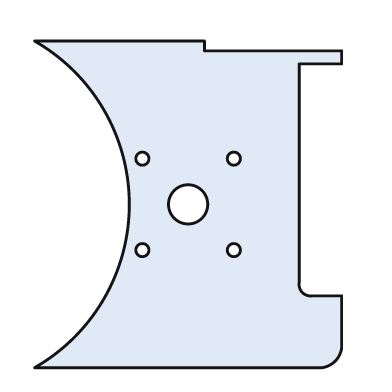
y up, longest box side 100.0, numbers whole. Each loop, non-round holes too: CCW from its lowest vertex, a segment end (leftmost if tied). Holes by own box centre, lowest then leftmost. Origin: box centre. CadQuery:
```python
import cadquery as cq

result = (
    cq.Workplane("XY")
    .moveTo(-47.0, -50.0)
    .lineTo(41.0, -50.0)
    .threePointArc((45.0, -48.0), (47.0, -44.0))
    .lineTo(47.0, -28.0)
    .lineTo(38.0, -28.0)
    .threePointArc((35.0, -27.0), (34.0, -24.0))
    .lineTo(34.0, 43.0)
    .lineTo(47.0, 43.0)
    .lineTo(47.0, 47.0)
    .lineTo(5.0, 47.0)
    .lineTo(5.0, 50.0)
    .lineTo(-47.0, 50.0)
    .threePointArc((-18.0, 0.0), (-47.0, -50.0))
    .close()
    .moveTo(-14.0, -14.0)
    .circle(2.0)
    .moveTo(14.0, -14.0)
    .circle(2.0)
    .moveTo(0.0, 0.0)
    .circle(6.0)
    .moveTo(-14.0, 14.0)
    .circle(2.0)
    .moveTo(14.0, 14.0)
    .circle(2.0)
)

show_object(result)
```